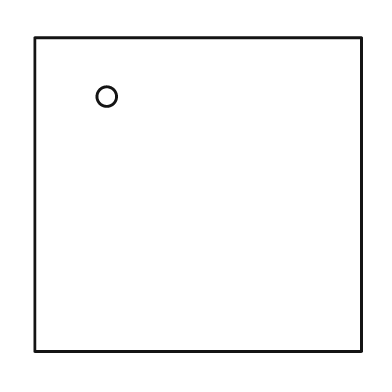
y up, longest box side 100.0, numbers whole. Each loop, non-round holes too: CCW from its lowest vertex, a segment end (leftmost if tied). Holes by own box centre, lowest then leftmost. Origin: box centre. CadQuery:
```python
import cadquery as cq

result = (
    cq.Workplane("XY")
    .moveTo(-50.0, -48.0)
    .lineTo(50.0, -48.0)
    .lineTo(50.0, 48.0)
    .lineTo(-50.0, 48.0)
    .close()
    .moveTo(-28.0, 30.0)
    .circle(3.0)
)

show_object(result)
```